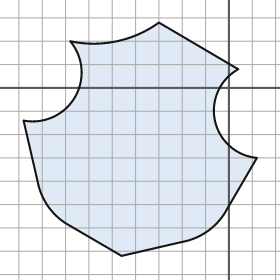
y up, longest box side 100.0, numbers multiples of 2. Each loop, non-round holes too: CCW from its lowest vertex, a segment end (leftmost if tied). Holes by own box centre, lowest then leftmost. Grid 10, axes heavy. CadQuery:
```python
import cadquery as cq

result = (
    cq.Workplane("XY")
    .moveTo(-46.0, -72.0)
    .lineTo(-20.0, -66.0)
    .threePointArc((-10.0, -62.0), (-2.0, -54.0))
    .lineTo(12.0, -30.0)
    .threePointArc((-6.0, -14.0), (4.0, 8.0))
    .lineTo(-30.0, 28.0)
    .threePointArc((-48.0, 20.0), (-68.0, 20.0))
    .threePointArc((-66.0, -4.0), (-88.0, -14.0))
    .lineTo(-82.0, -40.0)
    .threePointArc((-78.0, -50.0), (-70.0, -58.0))
    .close()
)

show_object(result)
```